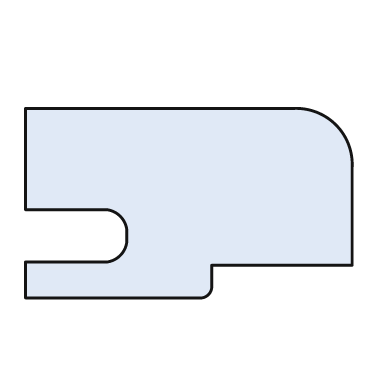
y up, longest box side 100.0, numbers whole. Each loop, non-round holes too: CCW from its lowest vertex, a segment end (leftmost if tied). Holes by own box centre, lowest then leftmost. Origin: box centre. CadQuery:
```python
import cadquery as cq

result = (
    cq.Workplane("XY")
    .moveTo(-50.0, -29.0)
    .lineTo(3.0, -29.0)
    .threePointArc((6.0, -28.0), (7.0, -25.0))
    .lineTo(7.0, -19.0)
    .lineTo(50.0, -19.0)
    .lineTo(50.0, 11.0)
    .threePointArc((45.0, 24.0), (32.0, 29.0))
    .lineTo(-50.0, 29.0)
    .lineTo(-50.0, -2.0)
    .lineTo(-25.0, -2.0)
    .threePointArc((-21.0, -4.0), (-19.0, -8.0))
    .lineTo(-19.0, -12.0)
    .threePointArc((-21.0, -16.0), (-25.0, -18.0))
    .lineTo(-50.0, -18.0)
    .close()
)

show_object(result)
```